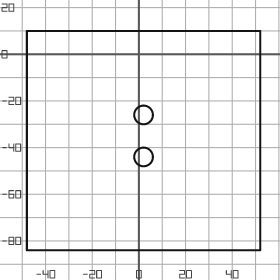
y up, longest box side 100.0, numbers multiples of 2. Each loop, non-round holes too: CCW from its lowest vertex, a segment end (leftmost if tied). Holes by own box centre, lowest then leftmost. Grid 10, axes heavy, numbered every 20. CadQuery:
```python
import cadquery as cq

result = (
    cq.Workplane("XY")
    .moveTo(-48.0, -84.0)
    .lineTo(52.0, -84.0)
    .lineTo(52.0, 10.0)
    .lineTo(-48.0, 10.0)
    .close()
    .moveTo(2.0, -44.0)
    .circle(4.0)
    .moveTo(2.0, -26.0)
    .circle(4.0)
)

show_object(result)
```